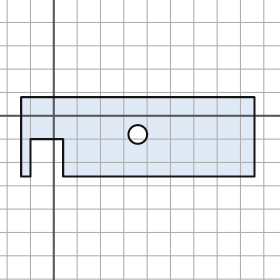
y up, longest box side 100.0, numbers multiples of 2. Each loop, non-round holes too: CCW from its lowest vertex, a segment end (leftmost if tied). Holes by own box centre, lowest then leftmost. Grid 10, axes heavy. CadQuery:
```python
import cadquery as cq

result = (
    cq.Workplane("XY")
    .moveTo(-14.0, -26.0)
    .lineTo(-10.0, -26.0)
    .lineTo(-10.0, -10.0)
    .lineTo(4.0, -10.0)
    .lineTo(4.0, -26.0)
    .lineTo(86.0, -26.0)
    .lineTo(86.0, 8.0)
    .lineTo(-14.0, 8.0)
    .close()
    .moveTo(36.0, -8.0)
    .circle(4.0)
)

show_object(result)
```